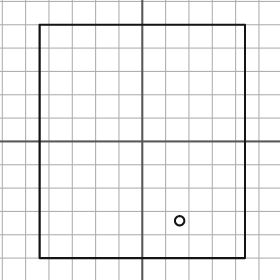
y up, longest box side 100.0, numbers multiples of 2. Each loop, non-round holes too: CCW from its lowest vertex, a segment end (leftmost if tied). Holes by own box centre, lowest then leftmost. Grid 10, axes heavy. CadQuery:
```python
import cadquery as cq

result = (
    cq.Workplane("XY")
    .moveTo(-44.0, -50.0)
    .lineTo(44.0, -50.0)
    .lineTo(44.0, 50.0)
    .lineTo(-44.0, 50.0)
    .close()
    .moveTo(16.0, -34.0)
    .circle(2.0)
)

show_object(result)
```